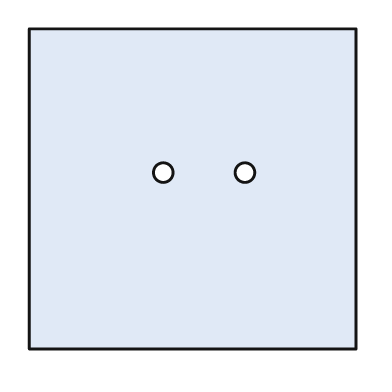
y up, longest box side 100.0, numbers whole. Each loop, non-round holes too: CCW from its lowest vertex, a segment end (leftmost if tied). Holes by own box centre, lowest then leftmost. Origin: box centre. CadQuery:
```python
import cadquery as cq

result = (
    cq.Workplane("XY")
    .moveTo(-50.0, -49.0)
    .lineTo(50.0, -49.0)
    .lineTo(50.0, 49.0)
    .lineTo(-50.0, 49.0)
    .close()
    .moveTo(-9.0, 5.0)
    .circle(3.0)
    .moveTo(16.0, 5.0)
    .circle(3.0)
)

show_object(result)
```